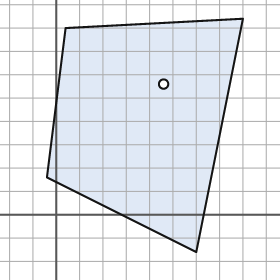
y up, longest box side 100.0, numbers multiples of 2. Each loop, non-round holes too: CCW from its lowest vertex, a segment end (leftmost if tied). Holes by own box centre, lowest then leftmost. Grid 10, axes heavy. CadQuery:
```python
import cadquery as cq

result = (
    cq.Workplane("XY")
    .moveTo(60.0, -16.0)
    .lineTo(80.0, 84.0)
    .lineTo(4.0, 80.0)
    .lineTo(-4.0, 16.0)
    .close()
    .moveTo(46.0, 56.0)
    .circle(2.0)
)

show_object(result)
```